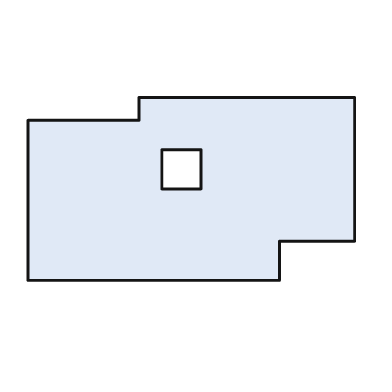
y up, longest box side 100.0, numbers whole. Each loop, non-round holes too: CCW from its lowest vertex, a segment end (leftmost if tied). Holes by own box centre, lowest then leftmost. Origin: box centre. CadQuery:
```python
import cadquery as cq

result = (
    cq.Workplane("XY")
    .moveTo(-50.0, -28.0)
    .lineTo(27.0, -28.0)
    .lineTo(27.0, -16.0)
    .lineTo(50.0, -16.0)
    .lineTo(50.0, 28.0)
    .lineTo(-16.0, 28.0)
    .lineTo(-16.0, 21.0)
    .lineTo(-50.0, 21.0)
    .close()
    .moveTo(-9.0, 0.0)
    .lineTo(3.0, 0.0)
    .lineTo(3.0, 12.0)
    .lineTo(-9.0, 12.0)
    .close()
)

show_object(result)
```